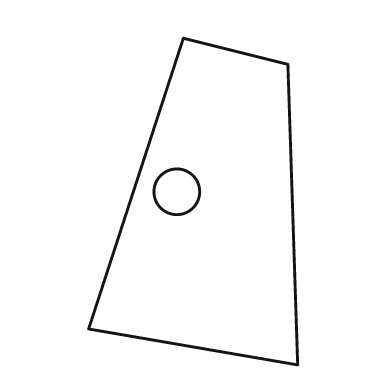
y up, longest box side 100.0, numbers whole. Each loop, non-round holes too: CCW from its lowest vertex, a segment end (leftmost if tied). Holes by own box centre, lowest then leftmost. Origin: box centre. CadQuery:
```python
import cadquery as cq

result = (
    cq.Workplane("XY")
    .moveTo(32.0, -50.0)
    .lineTo(29.0, 42.0)
    .lineTo(-3.0, 50.0)
    .lineTo(-32.0, -39.0)
    .close()
    .moveTo(-5.0, 3.0)
    .circle(7.0)
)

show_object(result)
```